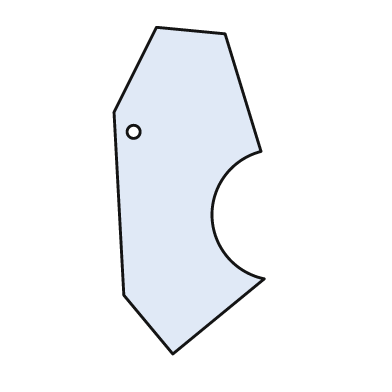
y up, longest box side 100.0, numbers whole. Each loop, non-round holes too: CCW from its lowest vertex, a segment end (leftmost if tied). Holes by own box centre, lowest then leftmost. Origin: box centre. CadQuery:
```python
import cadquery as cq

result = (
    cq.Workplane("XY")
    .moveTo(-5.0, -50.0)
    .lineTo(23.0, -27.0)
    .threePointArc((7.0, -8.0), (22.0, 12.0))
    .lineTo(11.0, 48.0)
    .lineTo(-10.0, 50.0)
    .lineTo(-23.0, 24.0)
    .lineTo(-20.0, -32.0)
    .close()
    .moveTo(-17.0, 18.0)
    .circle(2.0)
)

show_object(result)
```